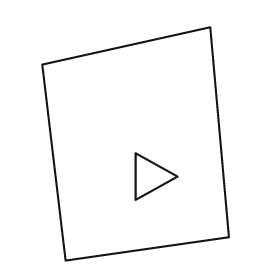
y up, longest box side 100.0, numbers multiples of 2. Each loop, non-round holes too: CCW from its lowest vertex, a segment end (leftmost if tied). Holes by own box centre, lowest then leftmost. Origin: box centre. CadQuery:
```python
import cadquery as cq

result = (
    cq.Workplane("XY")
    .moveTo(-30.0, -50.0)
    .lineTo(40.0, -40.0)
    .lineTo(32.0, 50.0)
    .lineTo(-40.0, 34.0)
    .close()
    .moveTo(0.0, -24.0)
    .lineTo(18.0, -14.0)
    .lineTo(0.0, -4.0)
    .close()
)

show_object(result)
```